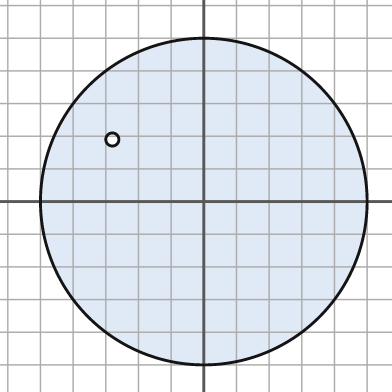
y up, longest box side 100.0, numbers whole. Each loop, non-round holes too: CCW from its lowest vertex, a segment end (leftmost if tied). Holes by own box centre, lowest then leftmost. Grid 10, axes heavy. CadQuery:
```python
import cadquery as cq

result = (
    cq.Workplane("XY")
    .moveTo(0.0, 0.0)
    .circle(50.0)
    .moveTo(-28.0, 19.0)
    .circle(2.0)
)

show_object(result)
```